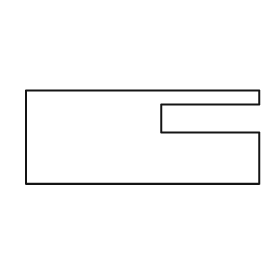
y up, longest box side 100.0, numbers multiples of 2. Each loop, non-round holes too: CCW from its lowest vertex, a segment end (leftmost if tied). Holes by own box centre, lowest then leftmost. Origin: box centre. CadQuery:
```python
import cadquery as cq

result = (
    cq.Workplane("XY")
    .moveTo(-50.0, -20.0)
    .lineTo(50.0, -20.0)
    .lineTo(50.0, 2.0)
    .lineTo(8.0, 2.0)
    .lineTo(8.0, 14.0)
    .lineTo(50.0, 14.0)
    .lineTo(50.0, 20.0)
    .lineTo(-50.0, 20.0)
    .close()
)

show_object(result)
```